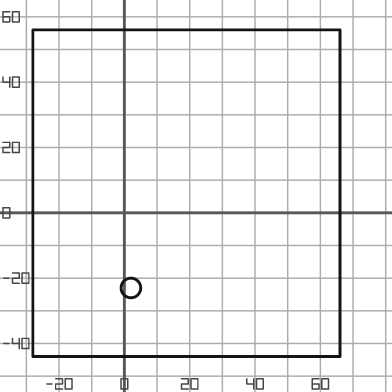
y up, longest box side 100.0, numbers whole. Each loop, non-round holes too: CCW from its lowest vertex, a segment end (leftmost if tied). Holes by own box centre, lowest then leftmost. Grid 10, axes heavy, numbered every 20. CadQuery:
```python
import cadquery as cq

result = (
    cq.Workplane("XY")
    .moveTo(-28.0, -44.0)
    .lineTo(66.0, -44.0)
    .lineTo(66.0, 56.0)
    .lineTo(-28.0, 56.0)
    .close()
    .moveTo(2.0, -23.0)
    .circle(3.0)
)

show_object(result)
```